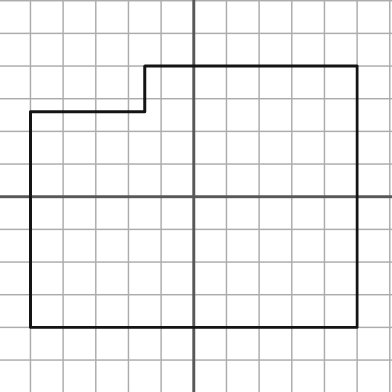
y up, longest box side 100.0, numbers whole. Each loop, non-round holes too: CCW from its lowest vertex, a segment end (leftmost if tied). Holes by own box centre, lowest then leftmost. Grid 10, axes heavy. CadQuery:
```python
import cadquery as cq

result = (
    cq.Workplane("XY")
    .moveTo(-50.0, -40.0)
    .lineTo(50.0, -40.0)
    .lineTo(50.0, 40.0)
    .lineTo(-15.0, 40.0)
    .lineTo(-15.0, 26.0)
    .lineTo(-50.0, 26.0)
    .close()
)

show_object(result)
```